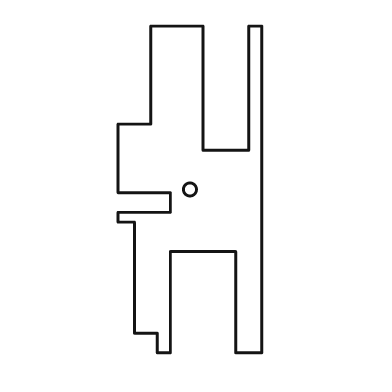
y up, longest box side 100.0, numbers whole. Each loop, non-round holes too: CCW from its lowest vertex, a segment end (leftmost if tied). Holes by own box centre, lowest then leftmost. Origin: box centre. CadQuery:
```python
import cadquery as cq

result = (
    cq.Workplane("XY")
    .moveTo(-10.0, -50.0)
    .lineTo(-6.0, -50.0)
    .lineTo(-6.0, -19.0)
    .lineTo(14.0, -19.0)
    .lineTo(14.0, -50.0)
    .lineTo(22.0, -50.0)
    .lineTo(22.0, 50.0)
    .lineTo(18.0, 50.0)
    .lineTo(18.0, 12.0)
    .lineTo(4.0, 12.0)
    .lineTo(4.0, 50.0)
    .lineTo(-12.0, 50.0)
    .lineTo(-12.0, 20.0)
    .lineTo(-22.0, 20.0)
    .lineTo(-22.0, -1.0)
    .lineTo(-6.0, -1.0)
    .lineTo(-6.0, -7.0)
    .lineTo(-22.0, -7.0)
    .lineTo(-22.0, -10.0)
    .lineTo(-17.0, -10.0)
    .lineTo(-17.0, -44.0)
    .lineTo(-10.0, -44.0)
    .close()
    .moveTo(0.0, 0.0)
    .circle(2.0)
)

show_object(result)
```